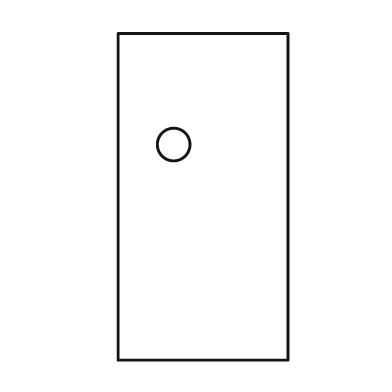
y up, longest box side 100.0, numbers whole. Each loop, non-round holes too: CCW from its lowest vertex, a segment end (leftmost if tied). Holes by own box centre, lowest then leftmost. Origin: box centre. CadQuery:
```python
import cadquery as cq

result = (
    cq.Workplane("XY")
    .moveTo(-26.0, -50.0)
    .lineTo(26.0, -50.0)
    .lineTo(26.0, 50.0)
    .lineTo(-26.0, 50.0)
    .close()
    .moveTo(-9.0, 16.0)
    .circle(5.0)
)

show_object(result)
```